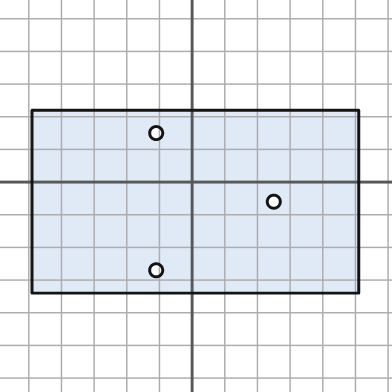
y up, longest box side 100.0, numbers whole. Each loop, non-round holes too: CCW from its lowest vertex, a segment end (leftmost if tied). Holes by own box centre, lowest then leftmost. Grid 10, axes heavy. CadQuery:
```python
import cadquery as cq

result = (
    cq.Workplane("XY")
    .moveTo(-49.0, -34.0)
    .lineTo(51.0, -34.0)
    .lineTo(51.0, 22.0)
    .lineTo(-49.0, 22.0)
    .close()
    .moveTo(-11.0, -27.0)
    .circle(2.0)
    .moveTo(25.0, -6.0)
    .circle(2.0)
    .moveTo(-11.0, 15.0)
    .circle(2.0)
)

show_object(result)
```